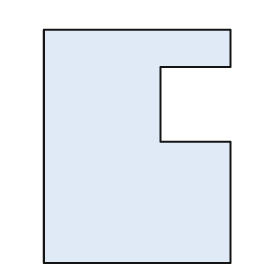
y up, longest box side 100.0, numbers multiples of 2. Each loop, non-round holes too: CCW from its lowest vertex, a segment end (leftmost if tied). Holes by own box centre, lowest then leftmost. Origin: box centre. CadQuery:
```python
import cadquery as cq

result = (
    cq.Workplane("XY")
    .moveTo(-40.0, -50.0)
    .lineTo(40.0, -50.0)
    .lineTo(40.0, 2.0)
    .lineTo(10.0, 2.0)
    .lineTo(10.0, 34.0)
    .lineTo(40.0, 34.0)
    .lineTo(40.0, 50.0)
    .lineTo(-40.0, 50.0)
    .close()
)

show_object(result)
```